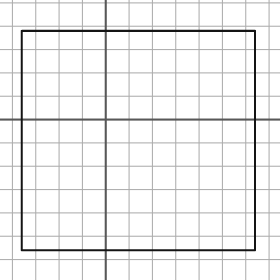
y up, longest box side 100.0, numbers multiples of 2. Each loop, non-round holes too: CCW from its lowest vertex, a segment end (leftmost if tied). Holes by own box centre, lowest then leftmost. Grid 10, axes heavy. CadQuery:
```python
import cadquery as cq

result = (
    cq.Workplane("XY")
    .moveTo(-36.0, -56.0)
    .lineTo(64.0, -56.0)
    .lineTo(64.0, 38.0)
    .lineTo(-36.0, 38.0)
    .close()
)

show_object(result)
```